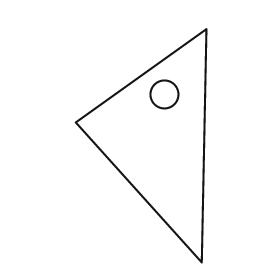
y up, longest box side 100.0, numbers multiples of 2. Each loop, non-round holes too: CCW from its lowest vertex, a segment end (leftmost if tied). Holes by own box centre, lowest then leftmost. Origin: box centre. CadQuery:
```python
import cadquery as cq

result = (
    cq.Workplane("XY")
    .moveTo(26.0, -50.0)
    .lineTo(28.0, 50.0)
    .lineTo(-28.0, 10.0)
    .close()
    .moveTo(10.0, 22.0)
    .circle(6.0)
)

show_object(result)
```